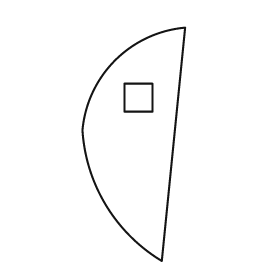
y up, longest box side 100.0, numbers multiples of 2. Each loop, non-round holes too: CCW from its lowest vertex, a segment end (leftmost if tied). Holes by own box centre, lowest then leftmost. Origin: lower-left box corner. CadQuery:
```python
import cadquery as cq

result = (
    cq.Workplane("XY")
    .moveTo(34.0, 0.0)
    .lineTo(44.0, 100.0)
    .threePointArc((14.0, 86.0), (0.0, 56.0))
    .threePointArc((10.0, 24.0), (34.0, 0.0))
    .close()
    .moveTo(18.0, 64.0)
    .lineTo(30.0, 64.0)
    .lineTo(30.0, 76.0)
    .lineTo(18.0, 76.0)
    .close()
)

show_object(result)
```